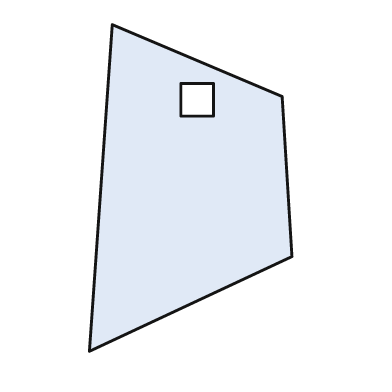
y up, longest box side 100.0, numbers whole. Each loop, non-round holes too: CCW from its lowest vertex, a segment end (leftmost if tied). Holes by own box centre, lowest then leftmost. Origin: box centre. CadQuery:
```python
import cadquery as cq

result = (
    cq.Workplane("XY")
    .moveTo(-31.0, -50.0)
    .lineTo(31.0, -21.0)
    .lineTo(28.0, 28.0)
    .lineTo(-24.0, 50.0)
    .close()
    .moveTo(-3.0, 22.0)
    .lineTo(7.0, 22.0)
    .lineTo(7.0, 32.0)
    .lineTo(-3.0, 32.0)
    .close()
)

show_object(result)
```